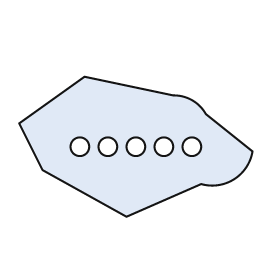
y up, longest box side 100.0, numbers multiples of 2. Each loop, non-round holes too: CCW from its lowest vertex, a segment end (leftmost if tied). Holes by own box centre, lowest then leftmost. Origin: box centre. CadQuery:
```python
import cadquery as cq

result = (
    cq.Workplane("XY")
    .moveTo(-4.0, -30.0)
    .lineTo(28.0, -16.0)
    .threePointArc((42.0, -14.0), (50.0, -2.0))
    .lineTo(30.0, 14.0)
    .threePointArc((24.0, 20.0), (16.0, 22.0))
    .lineTo(-22.0, 30.0)
    .lineTo(-50.0, 10.0)
    .lineTo(-40.0, -10.0)
    .close()
    .moveTo(-24.0, 0.0)
    .circle(4.0)
    .moveTo(-12.0, 0.0)
    .circle(4.0)
    .moveTo(0.0, 0.0)
    .circle(4.0)
    .moveTo(12.0, 0.0)
    .circle(4.0)
    .moveTo(24.0, 0.0)
    .circle(4.0)
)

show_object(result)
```